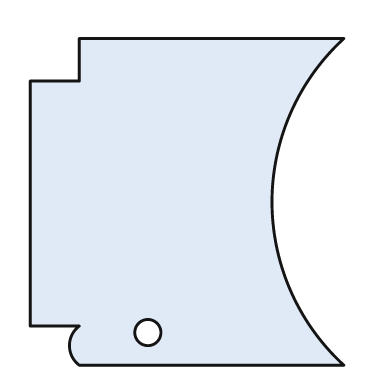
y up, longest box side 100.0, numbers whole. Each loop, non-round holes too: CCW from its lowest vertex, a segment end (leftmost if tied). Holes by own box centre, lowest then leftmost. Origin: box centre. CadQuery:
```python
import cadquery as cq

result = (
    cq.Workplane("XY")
    .moveTo(-33.0, -50.0)
    .lineTo(48.0, -50.0)
    .threePointArc((26.0, 0.0), (48.0, 50.0))
    .lineTo(-33.0, 50.0)
    .lineTo(-33.0, 37.0)
    .lineTo(-48.0, 37.0)
    .lineTo(-48.0, -38.0)
    .lineTo(-33.0, -38.0)
    .threePointArc((-36.0, -44.0), (-33.0, -50.0))
    .close()
    .moveTo(-12.0, -40.0)
    .circle(4.0)
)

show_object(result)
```